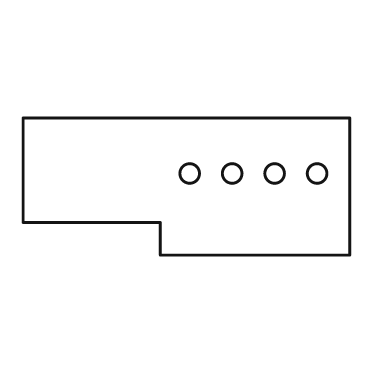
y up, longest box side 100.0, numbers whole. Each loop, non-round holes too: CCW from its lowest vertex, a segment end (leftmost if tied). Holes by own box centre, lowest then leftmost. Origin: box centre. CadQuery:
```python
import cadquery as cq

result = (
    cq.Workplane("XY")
    .moveTo(-8.0, -21.0)
    .lineTo(50.0, -21.0)
    .lineTo(50.0, 21.0)
    .lineTo(-50.0, 21.0)
    .lineTo(-50.0, -11.0)
    .lineTo(-8.0, -11.0)
    .close()
    .moveTo(1.0, 4.0)
    .circle(3.0)
    .moveTo(14.0, 4.0)
    .circle(3.0)
    .moveTo(27.0, 4.0)
    .circle(3.0)
    .moveTo(40.0, 4.0)
    .circle(3.0)
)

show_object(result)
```